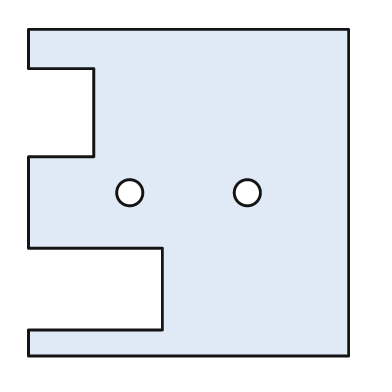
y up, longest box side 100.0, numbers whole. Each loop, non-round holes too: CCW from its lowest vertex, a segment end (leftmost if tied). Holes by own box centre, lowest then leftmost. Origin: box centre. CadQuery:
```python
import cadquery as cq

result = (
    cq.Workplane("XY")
    .moveTo(-49.0, -50.0)
    .lineTo(49.0, -50.0)
    .lineTo(49.0, 50.0)
    .lineTo(-49.0, 50.0)
    .lineTo(-49.0, 38.0)
    .lineTo(-29.0, 38.0)
    .lineTo(-29.0, 11.0)
    .lineTo(-49.0, 11.0)
    .lineTo(-49.0, -17.0)
    .lineTo(-8.0, -17.0)
    .lineTo(-8.0, -42.0)
    .lineTo(-49.0, -42.0)
    .close()
    .moveTo(-18.0, 0.0)
    .circle(4.0)
    .moveTo(18.0, 0.0)
    .circle(4.0)
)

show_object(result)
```